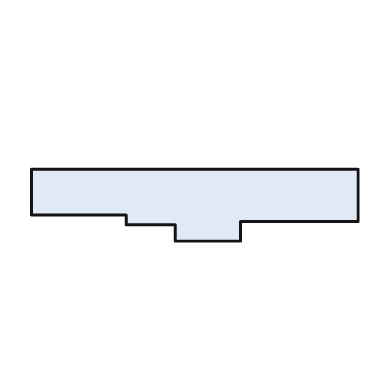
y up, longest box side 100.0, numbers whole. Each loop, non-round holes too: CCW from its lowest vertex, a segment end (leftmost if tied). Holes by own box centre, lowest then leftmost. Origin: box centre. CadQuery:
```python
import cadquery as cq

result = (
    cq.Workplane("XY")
    .moveTo(-6.0, -11.0)
    .lineTo(14.0, -11.0)
    .lineTo(14.0, -5.0)
    .lineTo(50.0, -5.0)
    .lineTo(50.0, 11.0)
    .lineTo(-50.0, 11.0)
    .lineTo(-50.0, -3.0)
    .lineTo(-21.0, -3.0)
    .lineTo(-21.0, -6.0)
    .lineTo(-6.0, -6.0)
    .close()
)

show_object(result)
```